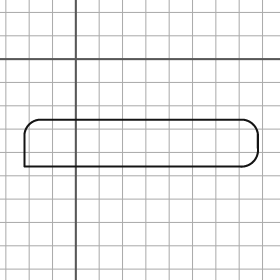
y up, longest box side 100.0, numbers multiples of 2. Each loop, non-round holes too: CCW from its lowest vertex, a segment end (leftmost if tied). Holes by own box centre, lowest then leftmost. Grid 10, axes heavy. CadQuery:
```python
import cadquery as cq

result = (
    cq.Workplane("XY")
    .moveTo(-22.0, -46.0)
    .lineTo(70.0, -46.0)
    .threePointArc((76.0, -44.0), (78.0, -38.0))
    .lineTo(78.0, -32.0)
    .threePointArc((76.0, -28.0), (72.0, -26.0))
    .lineTo(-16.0, -26.0)
    .threePointArc((-20.0, -28.0), (-22.0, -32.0))
    .close()
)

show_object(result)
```